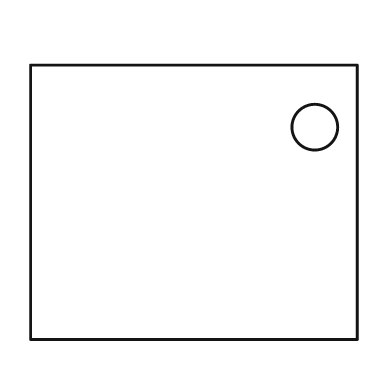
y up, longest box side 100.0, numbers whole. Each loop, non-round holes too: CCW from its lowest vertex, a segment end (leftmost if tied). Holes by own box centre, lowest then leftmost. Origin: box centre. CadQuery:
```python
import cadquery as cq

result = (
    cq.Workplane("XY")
    .moveTo(-50.0, -42.0)
    .lineTo(50.0, -42.0)
    .lineTo(50.0, 42.0)
    .lineTo(-50.0, 42.0)
    .close()
    .moveTo(37.0, 23.0)
    .circle(7.0)
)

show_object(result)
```